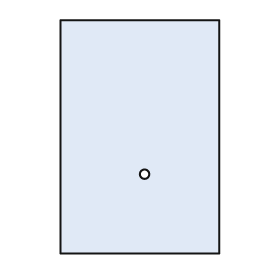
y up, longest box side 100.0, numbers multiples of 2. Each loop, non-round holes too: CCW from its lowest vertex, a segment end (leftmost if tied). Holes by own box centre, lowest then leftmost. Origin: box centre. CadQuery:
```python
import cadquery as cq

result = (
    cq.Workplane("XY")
    .moveTo(-34.0, -50.0)
    .lineTo(34.0, -50.0)
    .lineTo(34.0, 50.0)
    .lineTo(-34.0, 50.0)
    .close()
    .moveTo(2.0, -16.0)
    .circle(2.0)
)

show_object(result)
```